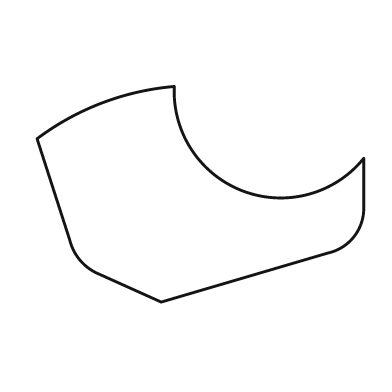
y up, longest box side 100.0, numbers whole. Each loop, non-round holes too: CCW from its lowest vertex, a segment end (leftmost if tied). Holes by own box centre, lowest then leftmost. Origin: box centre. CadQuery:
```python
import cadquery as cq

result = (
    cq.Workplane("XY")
    .moveTo(-12.0, -33.0)
    .lineTo(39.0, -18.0)
    .threePointArc((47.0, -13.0), (50.0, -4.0))
    .lineTo(50.0, 11.0)
    .threePointArc((13.0, 1.0), (-8.0, 33.0))
    .threePointArc((-30.0, 28.0), (-50.0, 17.0))
    .lineTo(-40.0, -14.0)
    .threePointArc((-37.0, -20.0), (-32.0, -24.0))
    .close()
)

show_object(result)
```